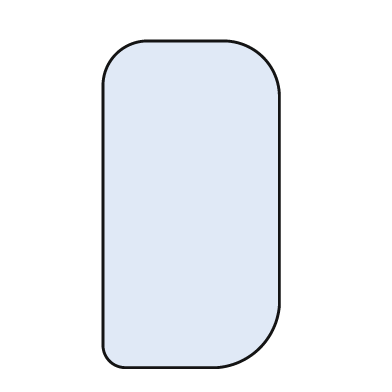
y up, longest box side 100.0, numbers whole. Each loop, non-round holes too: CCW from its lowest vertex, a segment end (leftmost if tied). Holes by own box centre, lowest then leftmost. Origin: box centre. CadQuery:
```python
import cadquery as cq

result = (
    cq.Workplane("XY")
    .moveTo(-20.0, -50.0)
    .lineTo(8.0, -50.0)
    .threePointArc((21.0, -44.0), (27.0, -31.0))
    .lineTo(27.0, 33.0)
    .threePointArc((22.0, 45.0), (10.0, 50.0))
    .lineTo(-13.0, 50.0)
    .threePointArc((-23.0, 46.0), (-27.0, 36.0))
    .lineTo(-27.0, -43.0)
    .threePointArc((-25.0, -48.0), (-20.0, -50.0))
    .close()
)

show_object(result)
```